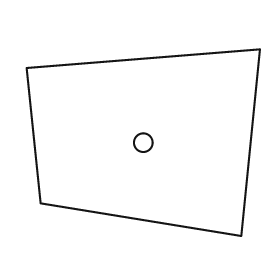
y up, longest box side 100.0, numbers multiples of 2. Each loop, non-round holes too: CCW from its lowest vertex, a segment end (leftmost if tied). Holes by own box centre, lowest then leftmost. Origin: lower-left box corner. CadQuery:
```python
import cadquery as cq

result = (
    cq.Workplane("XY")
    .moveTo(92.0, 0.0)
    .lineTo(100.0, 80.0)
    .lineTo(0.0, 72.0)
    .lineTo(6.0, 14.0)
    .close()
    .moveTo(50.0, 40.0)
    .circle(4.0)
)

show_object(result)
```